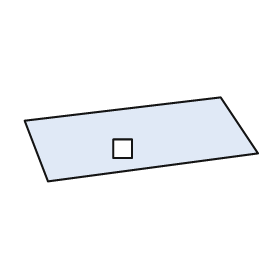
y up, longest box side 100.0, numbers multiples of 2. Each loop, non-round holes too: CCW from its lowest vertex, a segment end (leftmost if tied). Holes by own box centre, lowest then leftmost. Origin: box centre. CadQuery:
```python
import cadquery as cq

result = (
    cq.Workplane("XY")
    .moveTo(-40.0, -18.0)
    .lineTo(50.0, -6.0)
    .lineTo(34.0, 18.0)
    .lineTo(-50.0, 8.0)
    .close()
    .moveTo(-12.0, -8.0)
    .lineTo(-4.0, -8.0)
    .lineTo(-4.0, 0.0)
    .lineTo(-12.0, 0.0)
    .close()
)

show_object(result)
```